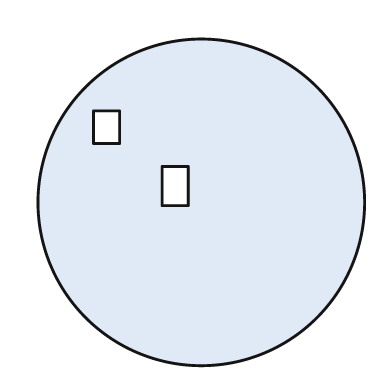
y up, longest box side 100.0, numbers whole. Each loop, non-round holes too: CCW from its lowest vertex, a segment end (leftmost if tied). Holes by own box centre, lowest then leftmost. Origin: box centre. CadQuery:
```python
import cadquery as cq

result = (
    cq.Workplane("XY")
    .moveTo(0.0, 0.0)
    .circle(50.0)
    .moveTo(-12.0, -1.0)
    .lineTo(-4.0, -1.0)
    .lineTo(-4.0, 11.0)
    .lineTo(-12.0, 11.0)
    .close()
    .moveTo(-33.0, 18.0)
    .lineTo(-25.0, 18.0)
    .lineTo(-25.0, 28.0)
    .lineTo(-33.0, 28.0)
    .close()
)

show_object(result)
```